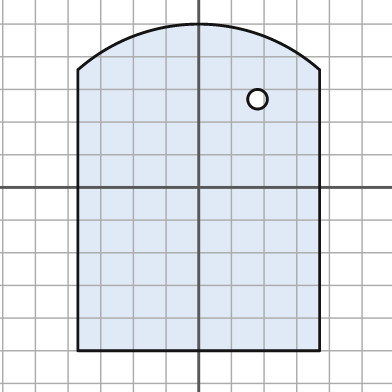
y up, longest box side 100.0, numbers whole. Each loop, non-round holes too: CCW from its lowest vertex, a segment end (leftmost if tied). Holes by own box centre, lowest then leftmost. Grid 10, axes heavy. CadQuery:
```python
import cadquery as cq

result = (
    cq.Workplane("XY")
    .moveTo(-37.0, -50.0)
    .lineTo(37.0, -50.0)
    .lineTo(37.0, 36.0)
    .threePointArc((0.0, 50.0), (-37.0, 36.0))
    .close()
    .moveTo(18.0, 27.0)
    .circle(3.0)
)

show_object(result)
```